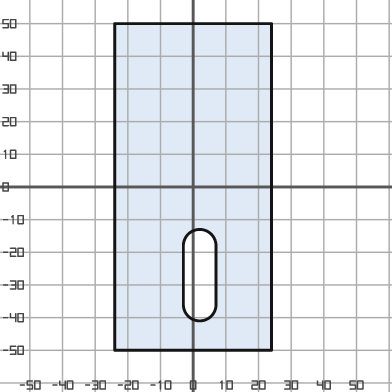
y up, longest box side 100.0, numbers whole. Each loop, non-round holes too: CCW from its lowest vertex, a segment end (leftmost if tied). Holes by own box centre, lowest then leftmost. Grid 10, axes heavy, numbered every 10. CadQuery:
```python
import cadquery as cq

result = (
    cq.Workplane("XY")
    .moveTo(-24.0, -50.0)
    .lineTo(24.0, -50.0)
    .lineTo(24.0, 50.0)
    .lineTo(-24.0, 50.0)
    .close()
    .moveTo(-3.0, -36.0)
    .threePointArc((2.0, -41.0), (7.0, -36.0))
    .lineTo(7.0, -18.0)
    .threePointArc((2.0, -13.0), (-3.0, -18.0))
    .close()
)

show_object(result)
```